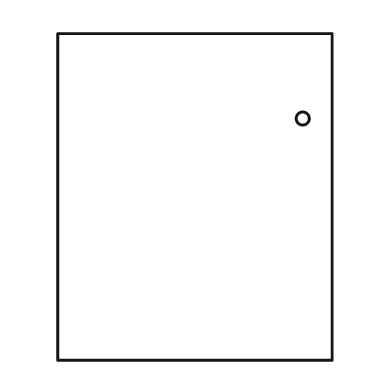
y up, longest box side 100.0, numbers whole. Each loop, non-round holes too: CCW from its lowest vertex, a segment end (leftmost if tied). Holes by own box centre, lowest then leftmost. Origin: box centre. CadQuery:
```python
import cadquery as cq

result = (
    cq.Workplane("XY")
    .moveTo(-42.0, -50.0)
    .lineTo(42.0, -50.0)
    .lineTo(42.0, 50.0)
    .lineTo(-42.0, 50.0)
    .close()
    .moveTo(33.0, 24.0)
    .circle(2.0)
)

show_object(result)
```